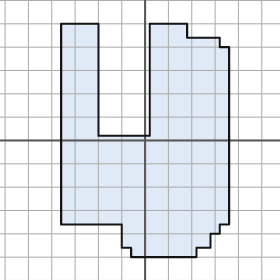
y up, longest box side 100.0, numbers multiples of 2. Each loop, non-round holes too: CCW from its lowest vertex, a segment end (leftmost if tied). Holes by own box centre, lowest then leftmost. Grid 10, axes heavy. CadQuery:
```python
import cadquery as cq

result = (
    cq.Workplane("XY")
    .moveTo(-6.0, -50.0)
    .lineTo(22.0, -50.0)
    .lineTo(22.0, -46.0)
    .lineTo(28.0, -46.0)
    .lineTo(28.0, -40.0)
    .lineTo(32.0, -40.0)
    .lineTo(32.0, -36.0)
    .lineTo(36.0, -36.0)
    .lineTo(36.0, 40.0)
    .lineTo(32.0, 40.0)
    .lineTo(32.0, 44.0)
    .lineTo(18.0, 44.0)
    .lineTo(18.0, 50.0)
    .lineTo(2.0, 50.0)
    .lineTo(2.0, 2.0)
    .lineTo(-20.0, 2.0)
    .lineTo(-20.0, 50.0)
    .lineTo(-36.0, 50.0)
    .lineTo(-36.0, -36.0)
    .lineTo(-10.0, -36.0)
    .lineTo(-10.0, -46.0)
    .lineTo(-6.0, -46.0)
    .close()
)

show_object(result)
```